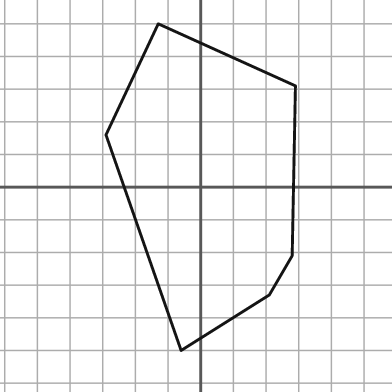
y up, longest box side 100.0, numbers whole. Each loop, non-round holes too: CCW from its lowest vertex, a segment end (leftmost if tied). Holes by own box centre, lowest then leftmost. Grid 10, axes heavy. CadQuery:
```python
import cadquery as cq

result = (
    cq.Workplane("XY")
    .moveTo(-6.0, -50.0)
    .lineTo(21.0, -33.0)
    .lineTo(28.0, -21.0)
    .lineTo(29.0, 31.0)
    .lineTo(-13.0, 50.0)
    .lineTo(-29.0, 16.0)
    .close()
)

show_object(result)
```